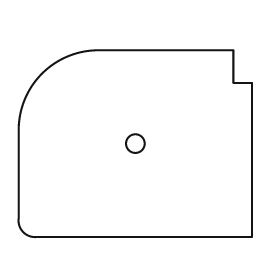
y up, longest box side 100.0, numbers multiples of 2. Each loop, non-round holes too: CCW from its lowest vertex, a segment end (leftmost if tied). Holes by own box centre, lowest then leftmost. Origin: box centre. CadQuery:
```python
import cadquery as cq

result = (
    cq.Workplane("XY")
    .moveTo(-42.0, -40.0)
    .lineTo(50.0, -40.0)
    .lineTo(50.0, 26.0)
    .lineTo(42.0, 26.0)
    .lineTo(42.0, 40.0)
    .lineTo(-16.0, 40.0)
    .threePointArc((-40.0, 30.0), (-50.0, 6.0))
    .lineTo(-50.0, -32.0)
    .threePointArc((-48.0, -38.0), (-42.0, -40.0))
    .close()
    .moveTo(0.0, 0.0)
    .circle(4.0)
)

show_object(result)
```